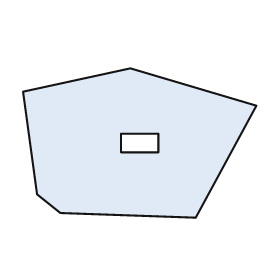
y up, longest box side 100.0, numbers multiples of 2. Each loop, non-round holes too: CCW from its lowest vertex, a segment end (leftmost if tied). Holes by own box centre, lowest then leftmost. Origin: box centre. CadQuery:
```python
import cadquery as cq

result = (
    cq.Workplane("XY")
    .moveTo(24.0, -32.0)
    .lineTo(50.0, 16.0)
    .lineTo(-4.0, 32.0)
    .lineTo(-50.0, 22.0)
    .lineTo(-44.0, -22.0)
    .lineTo(-34.0, -30.0)
    .close()
    .moveTo(-8.0, -4.0)
    .lineTo(8.0, -4.0)
    .lineTo(8.0, 4.0)
    .lineTo(-8.0, 4.0)
    .close()
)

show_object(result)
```